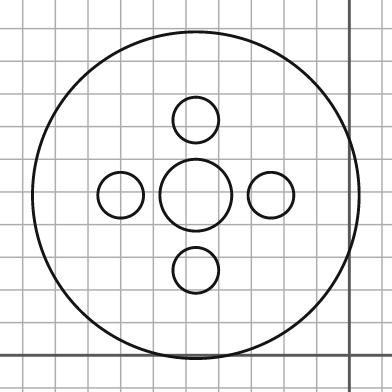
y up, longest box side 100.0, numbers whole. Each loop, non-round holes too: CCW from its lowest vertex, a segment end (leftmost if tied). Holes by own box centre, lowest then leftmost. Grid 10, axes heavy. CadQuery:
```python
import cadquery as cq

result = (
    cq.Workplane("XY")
    .moveTo(-47.0, 49.0)
    .circle(50.0)
    .moveTo(-47.0, 26.0)
    .circle(7.0)
    .moveTo(-70.0, 49.0)
    .circle(7.0)
    .moveTo(-47.0, 49.0)
    .circle(11.0)
    .moveTo(-24.0, 49.0)
    .circle(7.0)
    .moveTo(-47.0, 72.0)
    .circle(7.0)
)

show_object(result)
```